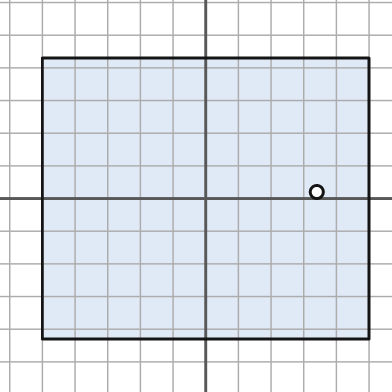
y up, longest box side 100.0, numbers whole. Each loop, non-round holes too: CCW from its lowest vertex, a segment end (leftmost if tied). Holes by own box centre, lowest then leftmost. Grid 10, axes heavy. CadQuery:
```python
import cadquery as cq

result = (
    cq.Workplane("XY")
    .moveTo(-50.0, -43.0)
    .lineTo(50.0, -43.0)
    .lineTo(50.0, 43.0)
    .lineTo(-50.0, 43.0)
    .close()
    .moveTo(34.0, 2.0)
    .circle(2.0)
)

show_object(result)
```